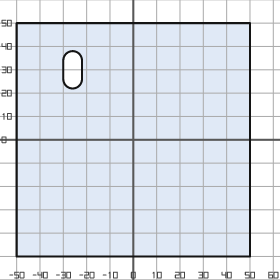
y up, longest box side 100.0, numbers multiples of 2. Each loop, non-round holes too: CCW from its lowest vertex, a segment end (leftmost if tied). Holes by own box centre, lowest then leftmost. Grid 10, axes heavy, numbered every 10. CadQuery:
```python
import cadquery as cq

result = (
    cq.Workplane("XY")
    .moveTo(-50.0, -50.0)
    .lineTo(50.0, -50.0)
    .lineTo(50.0, 50.0)
    .lineTo(-50.0, 50.0)
    .close()
    .moveTo(-30.0, 26.0)
    .threePointArc((-26.0, 22.0), (-22.0, 26.0))
    .lineTo(-22.0, 34.0)
    .threePointArc((-26.0, 38.0), (-30.0, 34.0))
    .close()
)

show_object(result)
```